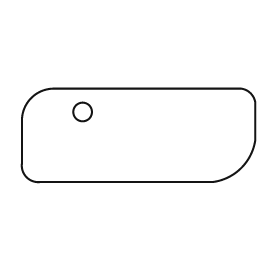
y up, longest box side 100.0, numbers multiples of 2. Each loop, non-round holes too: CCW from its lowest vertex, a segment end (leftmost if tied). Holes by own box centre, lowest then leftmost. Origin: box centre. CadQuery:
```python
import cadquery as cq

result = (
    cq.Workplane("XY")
    .moveTo(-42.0, -20.0)
    .lineTo(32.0, -20.0)
    .threePointArc((44.0, -14.0), (50.0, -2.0))
    .lineTo(50.0, 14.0)
    .threePointArc((48.0, 18.0), (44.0, 20.0))
    .lineTo(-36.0, 20.0)
    .threePointArc((-46.0, 16.0), (-50.0, 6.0))
    .lineTo(-50.0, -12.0)
    .threePointArc((-48.0, -18.0), (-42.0, -20.0))
    .close()
    .moveTo(-24.0, 10.0)
    .circle(4.0)
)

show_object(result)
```